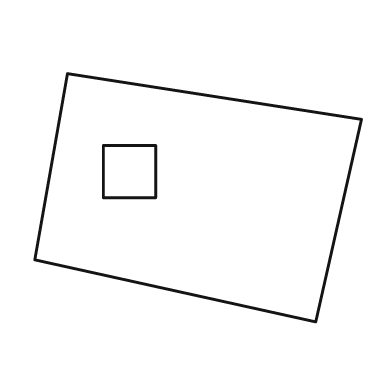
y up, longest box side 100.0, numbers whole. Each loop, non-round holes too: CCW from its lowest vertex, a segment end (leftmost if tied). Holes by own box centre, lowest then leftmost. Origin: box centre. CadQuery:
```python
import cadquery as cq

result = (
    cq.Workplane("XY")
    .moveTo(36.0, -38.0)
    .lineTo(50.0, 24.0)
    .lineTo(-40.0, 38.0)
    .lineTo(-50.0, -19.0)
    .close()
    .moveTo(-29.0, 0.0)
    .lineTo(-13.0, 0.0)
    .lineTo(-13.0, 16.0)
    .lineTo(-29.0, 16.0)
    .close()
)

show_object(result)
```